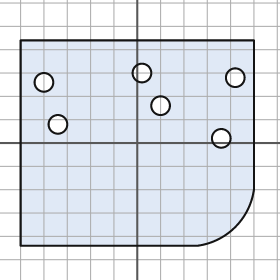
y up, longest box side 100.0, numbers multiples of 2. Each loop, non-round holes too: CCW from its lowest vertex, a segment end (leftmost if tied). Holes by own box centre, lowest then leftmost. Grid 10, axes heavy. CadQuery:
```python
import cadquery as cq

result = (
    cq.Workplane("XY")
    .moveTo(-50.0, -44.0)
    .lineTo(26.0, -44.0)
    .threePointArc((42.0, -36.0), (50.0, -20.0))
    .lineTo(50.0, 44.0)
    .lineTo(-50.0, 44.0)
    .close()
    .moveTo(36.0, 2.0)
    .circle(4.0)
    .moveTo(-34.0, 8.0)
    .circle(4.0)
    .moveTo(10.0, 16.0)
    .circle(4.0)
    .moveTo(-40.0, 26.0)
    .circle(4.0)
    .moveTo(42.0, 28.0)
    .circle(4.0)
    .moveTo(2.0, 30.0)
    .circle(4.0)
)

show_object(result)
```